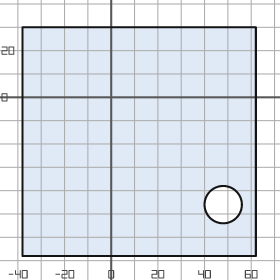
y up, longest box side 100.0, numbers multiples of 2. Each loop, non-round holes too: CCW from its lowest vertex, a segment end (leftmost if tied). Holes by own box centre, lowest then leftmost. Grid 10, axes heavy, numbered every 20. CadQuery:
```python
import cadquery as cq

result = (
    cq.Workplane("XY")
    .moveTo(-38.0, -68.0)
    .lineTo(62.0, -68.0)
    .lineTo(62.0, 30.0)
    .lineTo(-38.0, 30.0)
    .close()
    .moveTo(48.0, -46.0)
    .circle(8.0)
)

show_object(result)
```